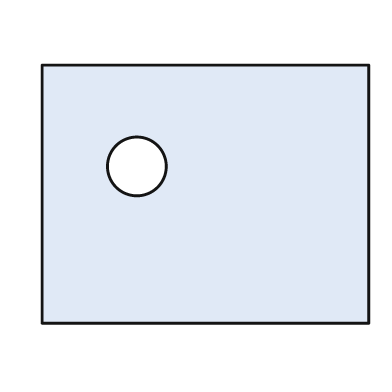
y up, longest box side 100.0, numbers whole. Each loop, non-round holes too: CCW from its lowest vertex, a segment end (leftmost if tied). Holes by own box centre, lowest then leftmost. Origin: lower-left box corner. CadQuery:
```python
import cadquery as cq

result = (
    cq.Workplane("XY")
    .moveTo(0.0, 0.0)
    .lineTo(100.0, 0.0)
    .lineTo(100.0, 79.0)
    .lineTo(0.0, 79.0)
    .close()
    .moveTo(29.0, 48.0)
    .circle(9.0)
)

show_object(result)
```